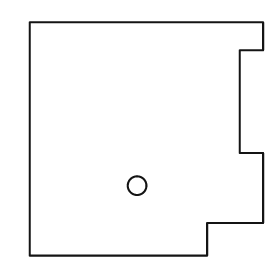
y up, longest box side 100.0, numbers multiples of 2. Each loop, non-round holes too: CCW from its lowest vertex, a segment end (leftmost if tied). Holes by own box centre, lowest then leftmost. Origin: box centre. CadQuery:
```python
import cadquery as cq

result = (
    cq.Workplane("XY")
    .moveTo(-50.0, -50.0)
    .lineTo(26.0, -50.0)
    .lineTo(26.0, -36.0)
    .lineTo(50.0, -36.0)
    .lineTo(50.0, -6.0)
    .lineTo(40.0, -6.0)
    .lineTo(40.0, 38.0)
    .lineTo(50.0, 38.0)
    .lineTo(50.0, 50.0)
    .lineTo(-50.0, 50.0)
    .close()
    .moveTo(-4.0, -20.0)
    .circle(4.0)
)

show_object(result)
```